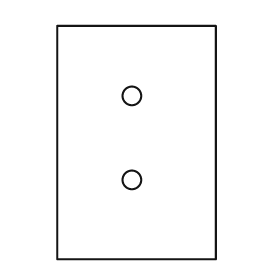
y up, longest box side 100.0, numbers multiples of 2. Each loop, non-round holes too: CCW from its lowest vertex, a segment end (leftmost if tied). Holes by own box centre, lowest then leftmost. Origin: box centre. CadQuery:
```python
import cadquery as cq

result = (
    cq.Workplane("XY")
    .moveTo(-34.0, -50.0)
    .lineTo(34.0, -50.0)
    .lineTo(34.0, 50.0)
    .lineTo(-34.0, 50.0)
    .close()
    .moveTo(-2.0, -16.0)
    .circle(4.0)
    .moveTo(-2.0, 20.0)
    .circle(4.0)
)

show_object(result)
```